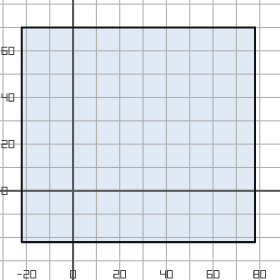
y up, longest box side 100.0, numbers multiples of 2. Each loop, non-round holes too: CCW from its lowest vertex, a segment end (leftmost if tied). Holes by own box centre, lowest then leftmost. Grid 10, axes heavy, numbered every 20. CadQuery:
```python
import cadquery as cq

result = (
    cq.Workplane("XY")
    .moveTo(-22.0, -22.0)
    .lineTo(78.0, -22.0)
    .lineTo(78.0, 70.0)
    .lineTo(-22.0, 70.0)
    .close()
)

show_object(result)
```